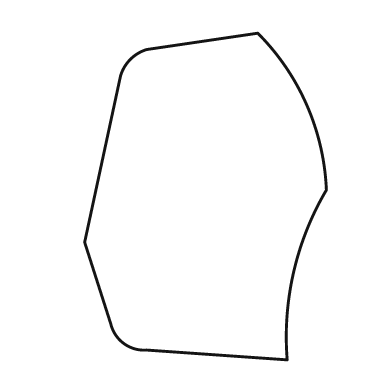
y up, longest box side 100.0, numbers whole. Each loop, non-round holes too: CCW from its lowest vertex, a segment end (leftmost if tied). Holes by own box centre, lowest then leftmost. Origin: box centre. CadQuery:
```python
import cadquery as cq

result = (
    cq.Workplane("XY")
    .moveTo(25.0, -50.0)
    .threePointArc((27.0, -23.0), (37.0, 2.0))
    .threePointArc((31.0, 28.0), (16.0, 50.0))
    .lineTo(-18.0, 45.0)
    .threePointArc((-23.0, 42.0), (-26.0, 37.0))
    .lineTo(-37.0, -14.0)
    .lineTo(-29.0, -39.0)
    .threePointArc((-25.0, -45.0), (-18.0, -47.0))
    .close()
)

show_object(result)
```